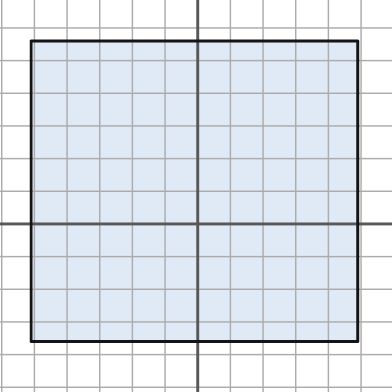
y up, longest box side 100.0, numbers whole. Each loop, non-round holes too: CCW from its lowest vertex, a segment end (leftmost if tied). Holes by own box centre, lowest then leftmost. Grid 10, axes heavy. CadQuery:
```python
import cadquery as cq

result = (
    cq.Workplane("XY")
    .moveTo(-51.0, -36.0)
    .lineTo(49.0, -36.0)
    .lineTo(49.0, 56.0)
    .lineTo(-51.0, 56.0)
    .close()
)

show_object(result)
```